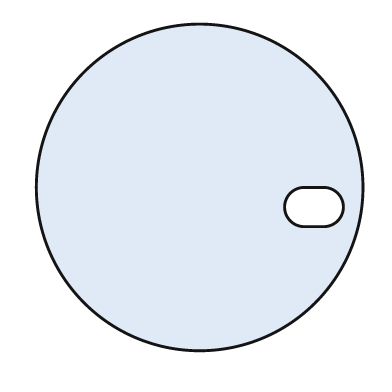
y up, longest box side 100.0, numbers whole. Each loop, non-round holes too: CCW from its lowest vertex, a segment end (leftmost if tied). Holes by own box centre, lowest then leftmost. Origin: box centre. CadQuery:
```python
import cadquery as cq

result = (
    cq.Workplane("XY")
    .moveTo(0.0, 0.0)
    .circle(50.0)
    .moveTo(32.0, -12.0)
    .lineTo(38.0, -12.0)
    .threePointArc((44.0, -6.0), (38.0, 0.0))
    .lineTo(32.0, 0.0)
    .threePointArc((26.0, -6.0), (32.0, -12.0))
    .close()
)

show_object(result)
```